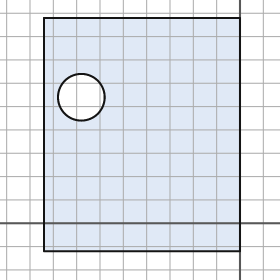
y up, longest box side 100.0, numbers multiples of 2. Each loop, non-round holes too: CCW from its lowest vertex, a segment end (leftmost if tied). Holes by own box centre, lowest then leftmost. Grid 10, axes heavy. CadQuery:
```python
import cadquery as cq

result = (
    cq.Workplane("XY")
    .moveTo(-84.0, -12.0)
    .lineTo(0.0, -12.0)
    .lineTo(0.0, 88.0)
    .lineTo(-84.0, 88.0)
    .close()
    .moveTo(-68.0, 54.0)
    .circle(10.0)
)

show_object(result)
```